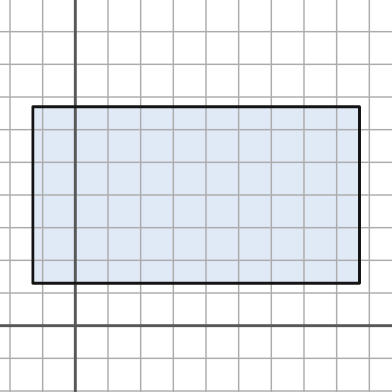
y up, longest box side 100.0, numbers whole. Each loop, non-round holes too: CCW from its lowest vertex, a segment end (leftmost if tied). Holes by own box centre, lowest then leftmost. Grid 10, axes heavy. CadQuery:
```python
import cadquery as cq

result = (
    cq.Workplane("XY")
    .moveTo(-13.0, 13.0)
    .lineTo(87.0, 13.0)
    .lineTo(87.0, 67.0)
    .lineTo(-13.0, 67.0)
    .close()
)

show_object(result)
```